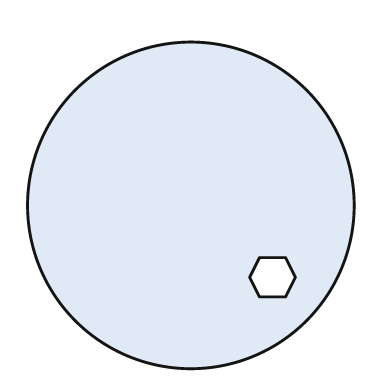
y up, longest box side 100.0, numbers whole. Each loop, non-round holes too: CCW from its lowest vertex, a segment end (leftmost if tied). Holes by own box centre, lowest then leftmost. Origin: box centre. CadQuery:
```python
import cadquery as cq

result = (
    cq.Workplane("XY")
    .moveTo(0.0, 0.0)
    .circle(50.0)
    .moveTo(21.0, -28.0)
    .lineTo(29.0, -28.0)
    .lineTo(32.0, -22.0)
    .lineTo(29.0, -16.0)
    .lineTo(21.0, -16.0)
    .lineTo(18.0, -22.0)
    .close()
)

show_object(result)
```